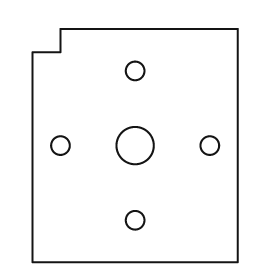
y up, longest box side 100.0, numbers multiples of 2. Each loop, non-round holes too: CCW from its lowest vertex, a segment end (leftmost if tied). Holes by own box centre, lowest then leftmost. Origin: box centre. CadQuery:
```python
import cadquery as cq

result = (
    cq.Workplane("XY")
    .moveTo(-44.0, -50.0)
    .lineTo(44.0, -50.0)
    .lineTo(44.0, 50.0)
    .lineTo(-32.0, 50.0)
    .lineTo(-32.0, 40.0)
    .lineTo(-44.0, 40.0)
    .close()
    .moveTo(0.0, -32.0)
    .circle(4.0)
    .moveTo(-32.0, 0.0)
    .circle(4.0)
    .moveTo(0.0, 0.0)
    .circle(8.0)
    .moveTo(32.0, 0.0)
    .circle(4.0)
    .moveTo(0.0, 32.0)
    .circle(4.0)
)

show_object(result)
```